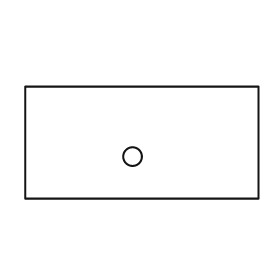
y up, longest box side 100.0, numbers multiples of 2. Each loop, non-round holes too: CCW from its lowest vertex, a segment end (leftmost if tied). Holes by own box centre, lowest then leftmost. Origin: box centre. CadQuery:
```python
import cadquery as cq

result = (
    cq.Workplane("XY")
    .moveTo(-50.0, -24.0)
    .lineTo(50.0, -24.0)
    .lineTo(50.0, 24.0)
    .lineTo(-50.0, 24.0)
    .close()
    .moveTo(-4.0, -6.0)
    .circle(4.0)
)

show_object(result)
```